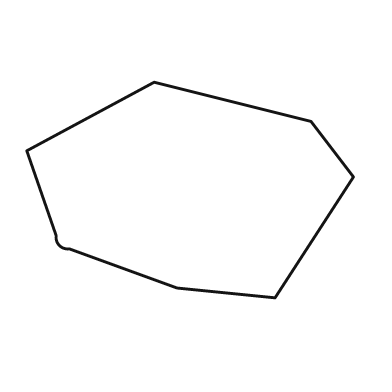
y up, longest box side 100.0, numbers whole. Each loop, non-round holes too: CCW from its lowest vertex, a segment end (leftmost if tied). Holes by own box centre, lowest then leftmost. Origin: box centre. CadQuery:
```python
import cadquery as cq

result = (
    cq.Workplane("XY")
    .moveTo(26.0, -33.0)
    .lineTo(50.0, 4.0)
    .lineTo(37.0, 21.0)
    .lineTo(-11.0, 33.0)
    .lineTo(-50.0, 12.0)
    .lineTo(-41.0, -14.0)
    .threePointArc((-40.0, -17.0), (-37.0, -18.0))
    .lineTo(-4.0, -30.0)
    .close()
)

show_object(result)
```